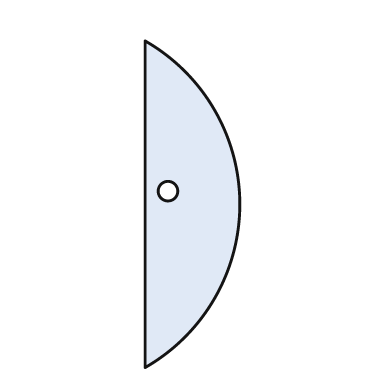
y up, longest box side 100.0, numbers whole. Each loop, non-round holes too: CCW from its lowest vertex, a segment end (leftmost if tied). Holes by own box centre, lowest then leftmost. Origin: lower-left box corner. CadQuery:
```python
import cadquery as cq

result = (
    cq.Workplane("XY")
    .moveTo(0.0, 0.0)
    .threePointArc((29.0, 50.0), (0.0, 100.0))
    .close()
    .moveTo(7.0, 54.0)
    .circle(3.0)
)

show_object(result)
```